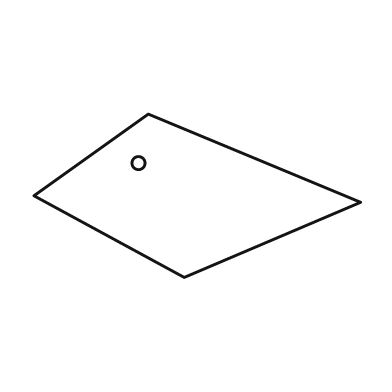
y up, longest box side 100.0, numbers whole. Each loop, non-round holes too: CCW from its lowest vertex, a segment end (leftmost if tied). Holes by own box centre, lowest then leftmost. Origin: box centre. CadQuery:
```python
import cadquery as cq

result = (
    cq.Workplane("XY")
    .moveTo(-4.0, -25.0)
    .lineTo(50.0, -2.0)
    .lineTo(-15.0, 25.0)
    .lineTo(-50.0, 0.0)
    .close()
    .moveTo(-18.0, 10.0)
    .circle(2.0)
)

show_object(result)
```